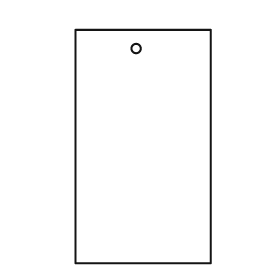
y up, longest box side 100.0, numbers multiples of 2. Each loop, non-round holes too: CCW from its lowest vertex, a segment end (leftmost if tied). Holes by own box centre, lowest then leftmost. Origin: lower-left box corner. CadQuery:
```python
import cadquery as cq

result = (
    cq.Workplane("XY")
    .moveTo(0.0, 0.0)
    .lineTo(58.0, 0.0)
    .lineTo(58.0, 100.0)
    .lineTo(0.0, 100.0)
    .close()
    .moveTo(26.0, 92.0)
    .circle(2.0)
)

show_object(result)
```